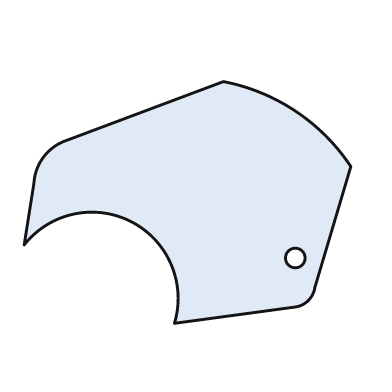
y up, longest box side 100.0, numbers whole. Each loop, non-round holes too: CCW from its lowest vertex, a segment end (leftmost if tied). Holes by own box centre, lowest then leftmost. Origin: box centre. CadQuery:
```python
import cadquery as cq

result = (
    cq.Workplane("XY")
    .moveTo(-4.0, -37.0)
    .lineTo(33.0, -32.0)
    .threePointArc((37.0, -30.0), (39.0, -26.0))
    .lineTo(50.0, 11.0)
    .threePointArc((33.0, 28.0), (11.0, 37.0))
    .lineTo(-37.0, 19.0)
    .threePointArc((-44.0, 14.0), (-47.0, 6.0))
    .lineTo(-50.0, -13.0)
    .threePointArc((-17.0, -6.0), (-4.0, -37.0))
    .close()
    .moveTo(33.0, -17.0)
    .circle(3.0)
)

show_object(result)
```